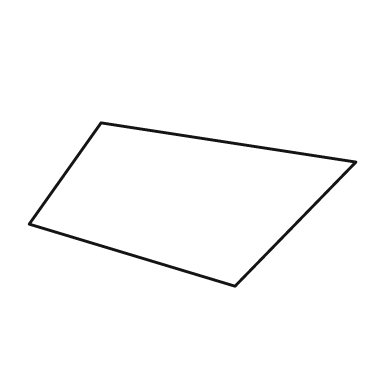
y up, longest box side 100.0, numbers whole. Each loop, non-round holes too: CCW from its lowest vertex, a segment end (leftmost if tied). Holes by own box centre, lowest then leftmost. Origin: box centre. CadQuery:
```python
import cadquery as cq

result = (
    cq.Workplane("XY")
    .moveTo(13.0, -25.0)
    .lineTo(50.0, 13.0)
    .lineTo(-28.0, 25.0)
    .lineTo(-50.0, -6.0)
    .close()
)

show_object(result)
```